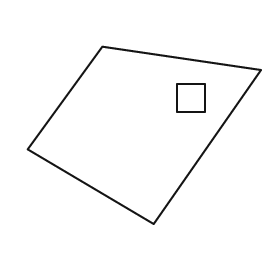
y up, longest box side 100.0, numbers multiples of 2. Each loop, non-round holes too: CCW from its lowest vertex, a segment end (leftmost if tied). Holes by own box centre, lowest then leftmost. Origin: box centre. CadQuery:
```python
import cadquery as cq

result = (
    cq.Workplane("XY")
    .moveTo(4.0, -38.0)
    .lineTo(50.0, 28.0)
    .lineTo(-18.0, 38.0)
    .lineTo(-50.0, -6.0)
    .close()
    .moveTo(14.0, 10.0)
    .lineTo(26.0, 10.0)
    .lineTo(26.0, 22.0)
    .lineTo(14.0, 22.0)
    .close()
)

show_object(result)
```